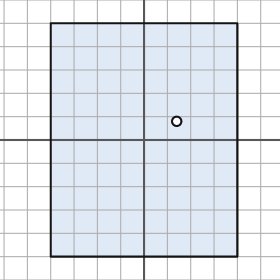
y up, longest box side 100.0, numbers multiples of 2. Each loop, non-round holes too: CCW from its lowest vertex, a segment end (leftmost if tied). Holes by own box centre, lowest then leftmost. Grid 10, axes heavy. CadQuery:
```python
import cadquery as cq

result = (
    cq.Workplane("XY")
    .moveTo(-40.0, -50.0)
    .lineTo(40.0, -50.0)
    .lineTo(40.0, 50.0)
    .lineTo(-40.0, 50.0)
    .close()
    .moveTo(14.0, 8.0)
    .circle(2.0)
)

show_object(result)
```